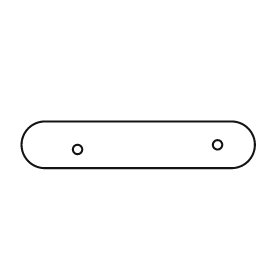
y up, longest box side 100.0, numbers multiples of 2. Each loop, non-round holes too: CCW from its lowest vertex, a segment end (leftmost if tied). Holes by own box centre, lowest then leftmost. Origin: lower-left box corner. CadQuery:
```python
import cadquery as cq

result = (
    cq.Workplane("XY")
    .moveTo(10.0, 0.0)
    .lineTo(90.0, 0.0)
    .threePointArc((100.0, 10.0), (90.0, 20.0))
    .lineTo(10.0, 20.0)
    .threePointArc((0.0, 10.0), (10.0, 0.0))
    .close()
    .moveTo(24.0, 8.0)
    .circle(2.0)
    .moveTo(84.0, 10.0)
    .circle(2.0)
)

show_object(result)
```